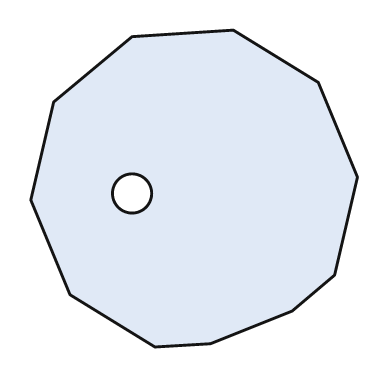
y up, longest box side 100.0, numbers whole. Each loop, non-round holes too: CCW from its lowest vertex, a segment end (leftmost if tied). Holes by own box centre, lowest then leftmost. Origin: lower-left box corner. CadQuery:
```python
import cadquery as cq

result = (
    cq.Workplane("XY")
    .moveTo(38.0, 0.0)
    .lineTo(55.0, 1.0)
    .lineTo(80.0, 11.0)
    .lineTo(93.0, 22.0)
    .lineTo(100.0, 52.0)
    .lineTo(88.0, 81.0)
    .lineTo(62.0, 97.0)
    .lineTo(31.0, 95.0)
    .lineTo(7.0, 75.0)
    .lineTo(0.0, 45.0)
    .lineTo(12.0, 16.0)
    .close()
    .moveTo(31.0, 47.0)
    .circle(6.0)
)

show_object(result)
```